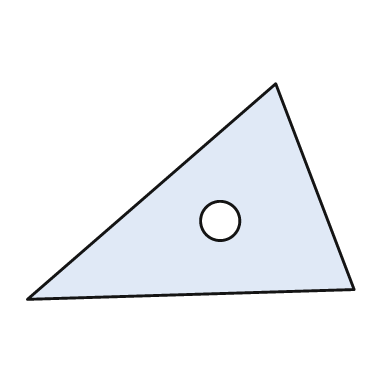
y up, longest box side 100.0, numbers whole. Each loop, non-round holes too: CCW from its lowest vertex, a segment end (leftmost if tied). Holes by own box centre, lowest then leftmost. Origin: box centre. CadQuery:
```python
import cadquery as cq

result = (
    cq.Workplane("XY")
    .moveTo(-50.0, -33.0)
    .lineTo(50.0, -30.0)
    .lineTo(26.0, 33.0)
    .close()
    .moveTo(9.0, -9.0)
    .circle(6.0)
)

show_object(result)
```